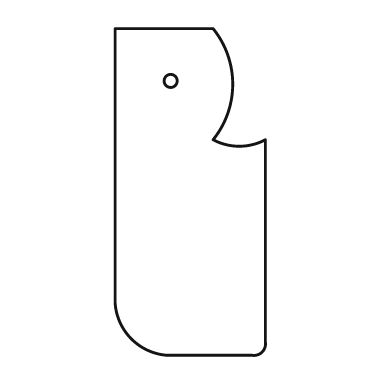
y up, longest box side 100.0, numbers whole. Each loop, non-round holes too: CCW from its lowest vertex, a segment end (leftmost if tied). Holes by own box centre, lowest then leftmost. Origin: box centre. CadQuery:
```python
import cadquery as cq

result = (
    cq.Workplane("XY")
    .moveTo(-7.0, -50.0)
    .lineTo(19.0, -50.0)
    .threePointArc((22.0, -49.0), (23.0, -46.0))
    .lineTo(23.0, 16.0)
    .threePointArc((15.0, 14.0), (7.0, 16.0))
    .threePointArc((13.0, 33.0), (7.0, 50.0))
    .lineTo(-23.0, 50.0)
    .lineTo(-23.0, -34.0)
    .threePointArc((-18.0, -45.0), (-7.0, -50.0))
    .close()
    .moveTo(-6.0, 34.0)
    .circle(2.0)
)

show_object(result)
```